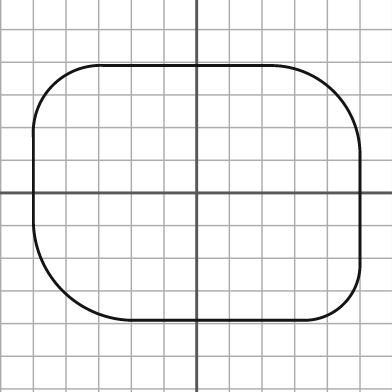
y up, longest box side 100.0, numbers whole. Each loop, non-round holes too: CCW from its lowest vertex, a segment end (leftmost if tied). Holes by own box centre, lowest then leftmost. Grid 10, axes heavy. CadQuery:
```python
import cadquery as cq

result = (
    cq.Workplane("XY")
    .moveTo(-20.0, -39.0)
    .lineTo(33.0, -39.0)
    .threePointArc((45.0, -34.0), (50.0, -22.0))
    .lineTo(50.0, 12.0)
    .threePointArc((42.0, 31.0), (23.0, 39.0))
    .lineTo(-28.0, 39.0)
    .threePointArc((-44.0, 33.0), (-50.0, 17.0))
    .lineTo(-50.0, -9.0)
    .threePointArc((-41.0, -30.0), (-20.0, -39.0))
    .close()
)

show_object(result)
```